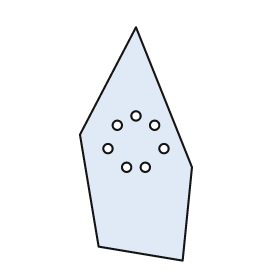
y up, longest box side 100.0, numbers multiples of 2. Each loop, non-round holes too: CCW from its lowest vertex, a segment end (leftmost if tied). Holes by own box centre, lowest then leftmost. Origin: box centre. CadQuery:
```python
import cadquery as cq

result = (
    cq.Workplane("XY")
    .moveTo(20.0, -50.0)
    .lineTo(24.0, -10.0)
    .lineTo(0.0, 50.0)
    .lineTo(-24.0, 4.0)
    .lineTo(-16.0, -44.0)
    .close()
    .moveTo(-4.0, -10.0)
    .circle(2.0)
    .moveTo(4.0, -10.0)
    .circle(2.0)
    .moveTo(-12.0, -2.0)
    .circle(2.0)
    .moveTo(12.0, -2.0)
    .circle(2.0)
    .moveTo(-8.0, 8.0)
    .circle(2.0)
    .moveTo(8.0, 8.0)
    .circle(2.0)
    .moveTo(0.0, 12.0)
    .circle(2.0)
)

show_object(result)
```